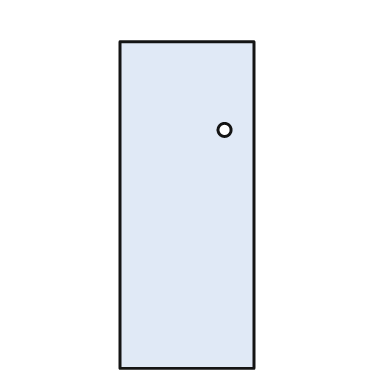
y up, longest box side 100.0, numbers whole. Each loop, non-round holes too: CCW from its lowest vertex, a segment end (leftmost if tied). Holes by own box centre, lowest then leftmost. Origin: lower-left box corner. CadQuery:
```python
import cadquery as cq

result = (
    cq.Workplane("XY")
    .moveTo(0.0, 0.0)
    .lineTo(41.0, 0.0)
    .lineTo(41.0, 100.0)
    .lineTo(0.0, 100.0)
    .close()
    .moveTo(32.0, 73.0)
    .circle(2.0)
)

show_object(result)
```